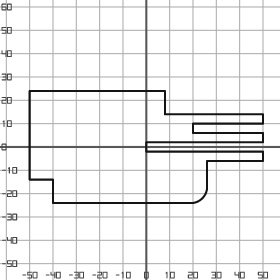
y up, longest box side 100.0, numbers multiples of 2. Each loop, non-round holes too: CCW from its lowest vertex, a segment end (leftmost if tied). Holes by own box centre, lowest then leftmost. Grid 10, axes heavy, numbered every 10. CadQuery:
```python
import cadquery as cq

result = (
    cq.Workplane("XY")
    .moveTo(-40.0, -24.0)
    .lineTo(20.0, -24.0)
    .threePointArc((24.0, -22.0), (26.0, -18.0))
    .lineTo(26.0, -6.0)
    .lineTo(50.0, -6.0)
    .lineTo(50.0, -2.0)
    .lineTo(0.0, -2.0)
    .lineTo(0.0, 2.0)
    .lineTo(50.0, 2.0)
    .lineTo(50.0, 6.0)
    .lineTo(20.0, 6.0)
    .lineTo(20.0, 10.0)
    .lineTo(50.0, 10.0)
    .lineTo(50.0, 14.0)
    .lineTo(8.0, 14.0)
    .lineTo(8.0, 24.0)
    .lineTo(-50.0, 24.0)
    .lineTo(-50.0, -14.0)
    .lineTo(-40.0, -14.0)
    .close()
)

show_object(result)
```